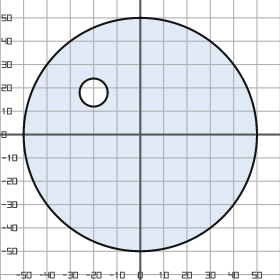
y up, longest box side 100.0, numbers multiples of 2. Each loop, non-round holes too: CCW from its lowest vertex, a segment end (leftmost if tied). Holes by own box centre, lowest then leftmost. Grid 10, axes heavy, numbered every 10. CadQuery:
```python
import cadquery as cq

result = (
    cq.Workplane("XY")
    .moveTo(0.0, 0.0)
    .circle(50.0)
    .moveTo(-20.0, 18.0)
    .circle(6.0)
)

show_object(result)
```